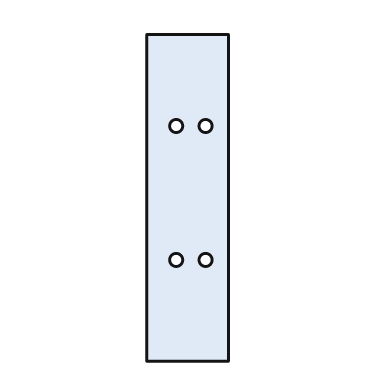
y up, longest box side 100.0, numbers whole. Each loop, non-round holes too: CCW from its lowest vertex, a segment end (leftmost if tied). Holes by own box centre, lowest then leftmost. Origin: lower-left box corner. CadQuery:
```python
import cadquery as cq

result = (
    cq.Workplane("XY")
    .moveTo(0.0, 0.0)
    .lineTo(25.0, 0.0)
    .lineTo(25.0, 100.0)
    .lineTo(0.0, 100.0)
    .close()
    .moveTo(9.0, 31.0)
    .circle(2.0)
    .moveTo(18.0, 31.0)
    .circle(2.0)
    .moveTo(9.0, 72.0)
    .circle(2.0)
    .moveTo(18.0, 72.0)
    .circle(2.0)
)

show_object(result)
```